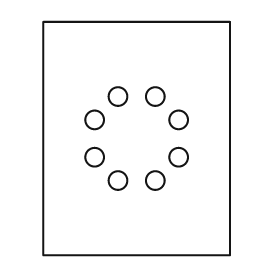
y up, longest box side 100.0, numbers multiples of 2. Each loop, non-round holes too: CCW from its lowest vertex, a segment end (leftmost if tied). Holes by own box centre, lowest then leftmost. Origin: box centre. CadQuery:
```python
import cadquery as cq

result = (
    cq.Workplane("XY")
    .moveTo(-40.0, -50.0)
    .lineTo(40.0, -50.0)
    .lineTo(40.0, 50.0)
    .lineTo(-40.0, 50.0)
    .close()
    .moveTo(-8.0, -18.0)
    .circle(4.0)
    .moveTo(8.0, -18.0)
    .circle(4.0)
    .moveTo(-18.0, -8.0)
    .circle(4.0)
    .moveTo(18.0, -8.0)
    .circle(4.0)
    .moveTo(-18.0, 8.0)
    .circle(4.0)
    .moveTo(18.0, 8.0)
    .circle(4.0)
    .moveTo(-8.0, 18.0)
    .circle(4.0)
    .moveTo(8.0, 18.0)
    .circle(4.0)
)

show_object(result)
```